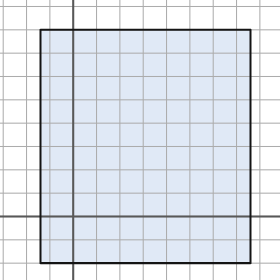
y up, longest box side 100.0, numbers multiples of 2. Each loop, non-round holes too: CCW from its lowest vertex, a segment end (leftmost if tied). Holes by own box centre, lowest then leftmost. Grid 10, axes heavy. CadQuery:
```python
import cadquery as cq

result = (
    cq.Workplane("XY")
    .moveTo(-14.0, -20.0)
    .lineTo(76.0, -20.0)
    .lineTo(76.0, 80.0)
    .lineTo(-14.0, 80.0)
    .close()
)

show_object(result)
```